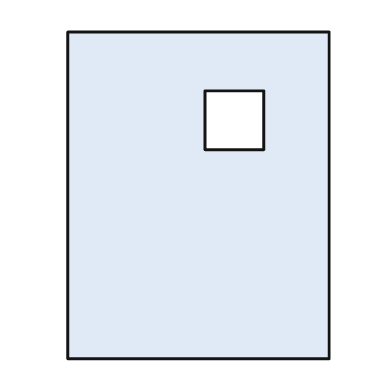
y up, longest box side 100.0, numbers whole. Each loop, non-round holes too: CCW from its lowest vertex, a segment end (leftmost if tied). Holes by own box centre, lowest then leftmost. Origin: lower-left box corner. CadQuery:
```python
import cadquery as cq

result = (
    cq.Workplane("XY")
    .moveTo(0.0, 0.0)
    .lineTo(80.0, 0.0)
    .lineTo(80.0, 100.0)
    .lineTo(0.0, 100.0)
    .close()
    .moveTo(42.0, 64.0)
    .lineTo(60.0, 64.0)
    .lineTo(60.0, 82.0)
    .lineTo(42.0, 82.0)
    .close()
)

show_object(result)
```